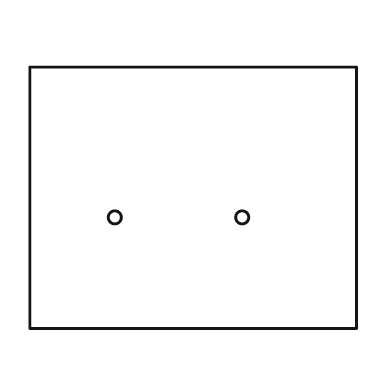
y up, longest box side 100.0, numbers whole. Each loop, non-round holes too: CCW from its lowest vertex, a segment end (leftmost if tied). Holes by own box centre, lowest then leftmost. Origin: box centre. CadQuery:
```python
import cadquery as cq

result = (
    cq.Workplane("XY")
    .moveTo(-50.0, -40.0)
    .lineTo(50.0, -40.0)
    .lineTo(50.0, 40.0)
    .lineTo(-50.0, 40.0)
    .close()
    .moveTo(-24.0, -6.0)
    .circle(2.0)
    .moveTo(15.0, -6.0)
    .circle(2.0)
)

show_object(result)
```